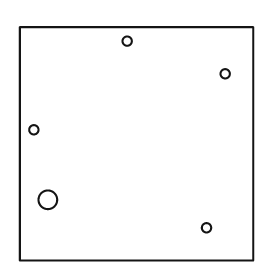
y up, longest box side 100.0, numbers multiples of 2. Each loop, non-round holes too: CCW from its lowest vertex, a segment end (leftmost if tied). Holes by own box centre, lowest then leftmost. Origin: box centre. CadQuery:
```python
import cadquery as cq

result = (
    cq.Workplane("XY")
    .moveTo(-50.0, -50.0)
    .lineTo(50.0, -50.0)
    .lineTo(50.0, 50.0)
    .lineTo(-50.0, 50.0)
    .close()
    .moveTo(30.0, -36.0)
    .circle(2.0)
    .moveTo(-38.0, -24.0)
    .circle(4.0)
    .moveTo(-44.0, 6.0)
    .circle(2.0)
    .moveTo(38.0, 30.0)
    .circle(2.0)
    .moveTo(-4.0, 44.0)
    .circle(2.0)
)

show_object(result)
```